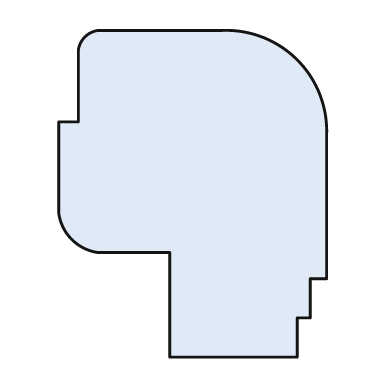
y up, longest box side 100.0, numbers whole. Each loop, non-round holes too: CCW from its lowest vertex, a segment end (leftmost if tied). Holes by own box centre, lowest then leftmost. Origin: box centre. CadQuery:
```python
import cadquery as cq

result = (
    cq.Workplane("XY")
    .moveTo(-7.0, -50.0)
    .lineTo(32.0, -50.0)
    .lineTo(32.0, -38.0)
    .lineTo(36.0, -38.0)
    .lineTo(36.0, -26.0)
    .lineTo(41.0, -26.0)
    .lineTo(41.0, 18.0)
    .threePointArc((32.0, 41.0), (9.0, 50.0))
    .lineTo(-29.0, 50.0)
    .threePointArc((-33.0, 48.0), (-35.0, 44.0))
    .lineTo(-35.0, 22.0)
    .lineTo(-41.0, 22.0)
    .lineTo(-41.0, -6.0)
    .threePointArc((-37.0, -14.0), (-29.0, -18.0))
    .lineTo(-7.0, -18.0)
    .close()
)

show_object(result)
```